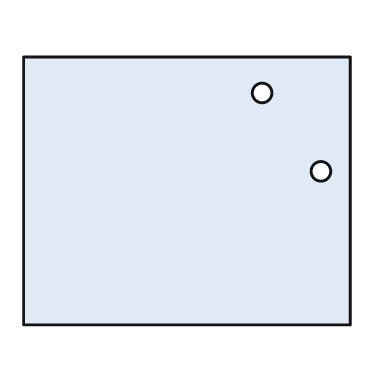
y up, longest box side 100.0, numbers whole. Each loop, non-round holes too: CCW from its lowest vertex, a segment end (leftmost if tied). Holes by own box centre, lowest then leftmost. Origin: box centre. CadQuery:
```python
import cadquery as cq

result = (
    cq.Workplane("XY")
    .moveTo(-50.0, -41.0)
    .lineTo(50.0, -41.0)
    .lineTo(50.0, 41.0)
    .lineTo(-50.0, 41.0)
    .close()
    .moveTo(41.0, 6.0)
    .circle(3.0)
    .moveTo(23.0, 30.0)
    .circle(3.0)
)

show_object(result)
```